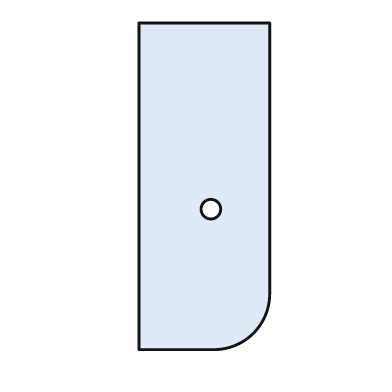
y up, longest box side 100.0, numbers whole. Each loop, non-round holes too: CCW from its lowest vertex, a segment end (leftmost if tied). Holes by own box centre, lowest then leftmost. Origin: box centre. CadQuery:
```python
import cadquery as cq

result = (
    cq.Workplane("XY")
    .moveTo(-20.0, -50.0)
    .lineTo(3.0, -50.0)
    .threePointArc((15.0, -45.0), (20.0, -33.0))
    .lineTo(20.0, 50.0)
    .lineTo(-20.0, 50.0)
    .close()
    .moveTo(2.0, -7.0)
    .circle(3.0)
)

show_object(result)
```